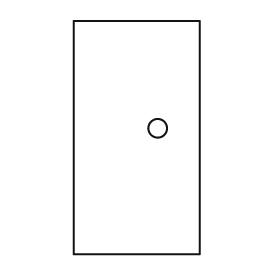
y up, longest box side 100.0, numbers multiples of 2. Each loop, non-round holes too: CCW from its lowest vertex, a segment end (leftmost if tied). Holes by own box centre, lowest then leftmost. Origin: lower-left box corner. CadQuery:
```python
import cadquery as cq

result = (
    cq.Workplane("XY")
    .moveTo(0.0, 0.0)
    .lineTo(54.0, 0.0)
    .lineTo(54.0, 100.0)
    .lineTo(0.0, 100.0)
    .close()
    .moveTo(36.0, 54.0)
    .circle(4.0)
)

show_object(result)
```